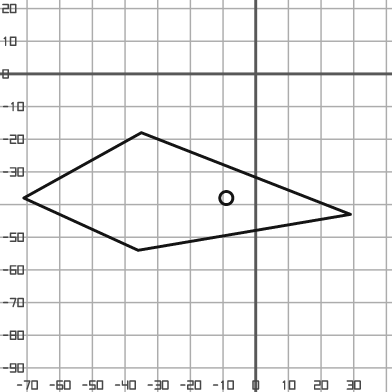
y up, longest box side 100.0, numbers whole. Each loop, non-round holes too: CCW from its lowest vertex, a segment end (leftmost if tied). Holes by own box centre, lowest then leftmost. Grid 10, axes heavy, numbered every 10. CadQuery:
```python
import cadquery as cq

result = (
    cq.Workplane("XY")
    .moveTo(-36.0, -54.0)
    .lineTo(29.0, -43.0)
    .lineTo(-35.0, -18.0)
    .lineTo(-71.0, -38.0)
    .close()
    .moveTo(-9.0, -38.0)
    .circle(2.0)
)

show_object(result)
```